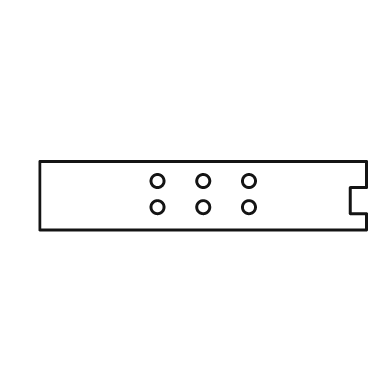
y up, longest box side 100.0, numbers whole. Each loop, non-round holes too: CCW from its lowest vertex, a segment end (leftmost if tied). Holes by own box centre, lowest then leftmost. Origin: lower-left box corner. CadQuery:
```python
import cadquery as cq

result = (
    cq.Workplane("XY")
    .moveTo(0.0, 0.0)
    .lineTo(100.0, 0.0)
    .lineTo(100.0, 5.0)
    .lineTo(95.0, 5.0)
    .lineTo(95.0, 13.0)
    .lineTo(100.0, 13.0)
    .lineTo(100.0, 21.0)
    .lineTo(0.0, 21.0)
    .close()
    .moveTo(36.0, 7.0)
    .circle(2.0)
    .moveTo(50.0, 7.0)
    .circle(2.0)
    .moveTo(64.0, 7.0)
    .circle(2.0)
    .moveTo(36.0, 15.0)
    .circle(2.0)
    .moveTo(50.0, 15.0)
    .circle(2.0)
    .moveTo(64.0, 15.0)
    .circle(2.0)
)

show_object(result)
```